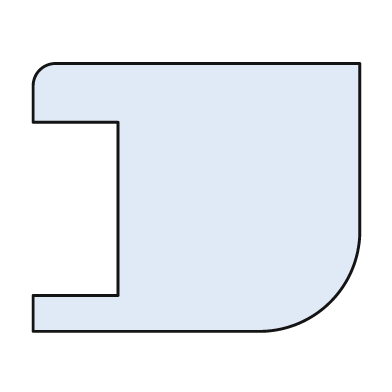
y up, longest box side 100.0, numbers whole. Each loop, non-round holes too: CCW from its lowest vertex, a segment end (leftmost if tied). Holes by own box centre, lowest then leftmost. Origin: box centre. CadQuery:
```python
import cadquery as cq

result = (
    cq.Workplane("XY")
    .moveTo(-50.0, -41.0)
    .lineTo(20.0, -41.0)
    .threePointArc((41.0, -32.0), (50.0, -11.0))
    .lineTo(50.0, 41.0)
    .lineTo(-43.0, 41.0)
    .threePointArc((-48.0, 39.0), (-50.0, 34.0))
    .lineTo(-50.0, 23.0)
    .lineTo(-24.0, 23.0)
    .lineTo(-24.0, -30.0)
    .lineTo(-50.0, -30.0)
    .close()
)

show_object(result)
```